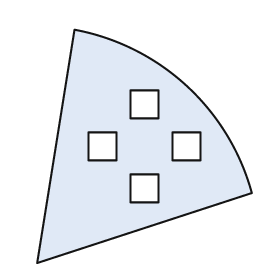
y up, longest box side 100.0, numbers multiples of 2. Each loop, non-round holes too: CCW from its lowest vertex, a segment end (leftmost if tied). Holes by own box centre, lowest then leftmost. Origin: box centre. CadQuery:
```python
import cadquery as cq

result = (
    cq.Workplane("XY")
    .moveTo(-46.0, -50.0)
    .lineTo(46.0, -20.0)
    .threePointArc((18.0, 26.0), (-30.0, 50.0))
    .close()
    .moveTo(-6.0, -24.0)
    .lineTo(6.0, -24.0)
    .lineTo(6.0, -12.0)
    .lineTo(-6.0, -12.0)
    .close()
    .moveTo(-24.0, -6.0)
    .lineTo(-12.0, -6.0)
    .lineTo(-12.0, 6.0)
    .lineTo(-24.0, 6.0)
    .close()
    .moveTo(12.0, -6.0)
    .lineTo(24.0, -6.0)
    .lineTo(24.0, 6.0)
    .lineTo(12.0, 6.0)
    .close()
    .moveTo(-6.0, 12.0)
    .lineTo(6.0, 12.0)
    .lineTo(6.0, 24.0)
    .lineTo(-6.0, 24.0)
    .close()
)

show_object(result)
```